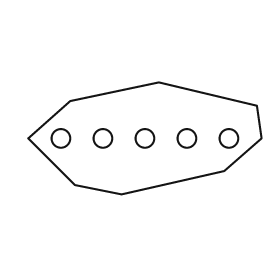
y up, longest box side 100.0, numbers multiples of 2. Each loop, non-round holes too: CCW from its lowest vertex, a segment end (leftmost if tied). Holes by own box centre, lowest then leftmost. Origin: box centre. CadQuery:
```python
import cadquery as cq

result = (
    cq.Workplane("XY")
    .moveTo(-10.0, -24.0)
    .lineTo(34.0, -14.0)
    .lineTo(50.0, 0.0)
    .lineTo(48.0, 14.0)
    .lineTo(6.0, 24.0)
    .lineTo(-32.0, 16.0)
    .lineTo(-50.0, 0.0)
    .lineTo(-30.0, -20.0)
    .close()
    .moveTo(-36.0, 0.0)
    .circle(4.0)
    .moveTo(-18.0, 0.0)
    .circle(4.0)
    .moveTo(0.0, 0.0)
    .circle(4.0)
    .moveTo(18.0, 0.0)
    .circle(4.0)
    .moveTo(36.0, 0.0)
    .circle(4.0)
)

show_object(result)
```